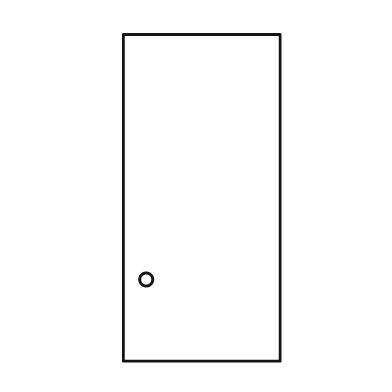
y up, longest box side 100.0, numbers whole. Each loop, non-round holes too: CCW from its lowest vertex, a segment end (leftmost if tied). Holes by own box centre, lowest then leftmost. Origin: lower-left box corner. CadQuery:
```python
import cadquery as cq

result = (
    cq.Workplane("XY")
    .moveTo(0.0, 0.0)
    .lineTo(48.0, 0.0)
    .lineTo(48.0, 100.0)
    .lineTo(0.0, 100.0)
    .close()
    .moveTo(7.0, 25.0)
    .circle(2.0)
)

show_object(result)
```